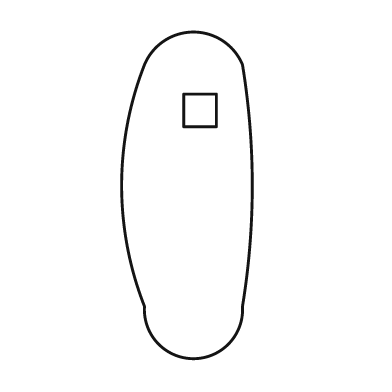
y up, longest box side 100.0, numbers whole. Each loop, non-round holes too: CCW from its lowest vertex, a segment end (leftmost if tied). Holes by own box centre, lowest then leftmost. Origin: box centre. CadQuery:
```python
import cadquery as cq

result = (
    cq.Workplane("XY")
    .moveTo(-13.0, -34.0)
    .threePointArc((2.0, -50.0), (17.0, -34.0))
    .threePointArc((20.0, 3.0), (17.0, 40.0))
    .threePointArc((2.0, 50.0), (-13.0, 40.0))
    .threePointArc((-20.0, 3.0), (-13.0, -34.0))
    .close()
    .moveTo(-1.0, 21.0)
    .lineTo(9.0, 21.0)
    .lineTo(9.0, 31.0)
    .lineTo(-1.0, 31.0)
    .close()
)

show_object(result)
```